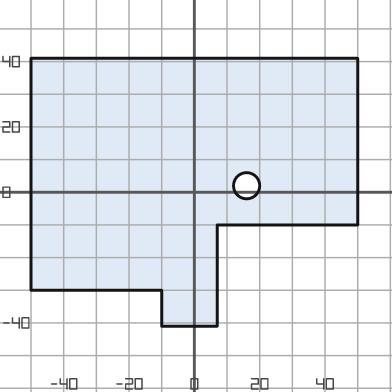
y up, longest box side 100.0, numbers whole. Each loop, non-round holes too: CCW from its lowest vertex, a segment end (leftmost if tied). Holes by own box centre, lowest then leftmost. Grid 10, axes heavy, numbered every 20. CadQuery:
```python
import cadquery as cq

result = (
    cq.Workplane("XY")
    .moveTo(-10.0, -41.0)
    .lineTo(7.0, -41.0)
    .lineTo(7.0, -10.0)
    .lineTo(50.0, -10.0)
    .lineTo(50.0, 41.0)
    .lineTo(-50.0, 41.0)
    .lineTo(-50.0, -30.0)
    .lineTo(-10.0, -30.0)
    .close()
    .moveTo(16.0, 2.0)
    .circle(4.0)
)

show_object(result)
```